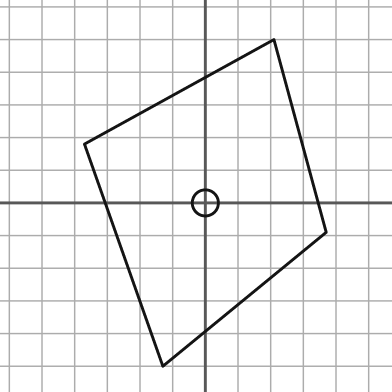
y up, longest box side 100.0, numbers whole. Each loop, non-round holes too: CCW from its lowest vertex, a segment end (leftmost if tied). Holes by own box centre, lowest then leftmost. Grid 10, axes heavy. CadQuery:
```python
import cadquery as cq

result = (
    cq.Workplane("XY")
    .moveTo(-13.0, -50.0)
    .lineTo(37.0, -9.0)
    .lineTo(21.0, 50.0)
    .lineTo(-37.0, 18.0)
    .close()
    .moveTo(0.0, 0.0)
    .circle(4.0)
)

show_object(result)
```